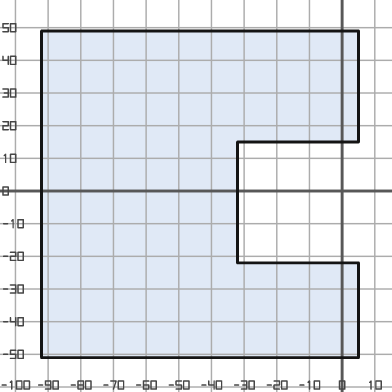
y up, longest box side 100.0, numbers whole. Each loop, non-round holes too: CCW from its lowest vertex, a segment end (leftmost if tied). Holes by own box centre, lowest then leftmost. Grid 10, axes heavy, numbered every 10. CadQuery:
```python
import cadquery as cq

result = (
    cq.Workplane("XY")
    .moveTo(-92.0, -51.0)
    .lineTo(5.0, -51.0)
    .lineTo(5.0, -22.0)
    .lineTo(-32.0, -22.0)
    .lineTo(-32.0, 15.0)
    .lineTo(5.0, 15.0)
    .lineTo(5.0, 49.0)
    .lineTo(-92.0, 49.0)
    .close()
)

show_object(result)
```